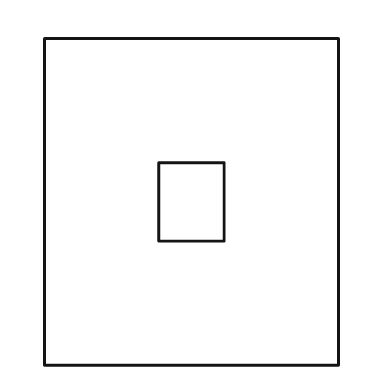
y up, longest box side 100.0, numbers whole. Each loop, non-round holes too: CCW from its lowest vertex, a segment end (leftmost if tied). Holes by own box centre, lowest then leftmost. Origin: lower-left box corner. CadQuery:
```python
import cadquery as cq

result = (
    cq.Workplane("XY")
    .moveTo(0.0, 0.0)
    .lineTo(90.0, 0.0)
    .lineTo(90.0, 100.0)
    .lineTo(0.0, 100.0)
    .close()
    .moveTo(35.0, 38.0)
    .lineTo(55.0, 38.0)
    .lineTo(55.0, 62.0)
    .lineTo(35.0, 62.0)
    .close()
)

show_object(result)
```